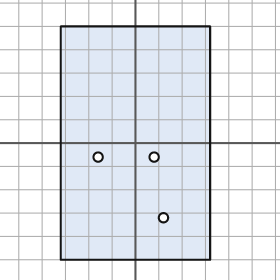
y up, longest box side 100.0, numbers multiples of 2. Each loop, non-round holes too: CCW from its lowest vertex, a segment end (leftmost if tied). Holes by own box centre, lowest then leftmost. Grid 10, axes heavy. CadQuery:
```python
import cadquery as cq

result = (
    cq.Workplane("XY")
    .moveTo(-32.0, -50.0)
    .lineTo(32.0, -50.0)
    .lineTo(32.0, 50.0)
    .lineTo(-32.0, 50.0)
    .close()
    .moveTo(12.0, -32.0)
    .circle(2.0)
    .moveTo(-16.0, -6.0)
    .circle(2.0)
    .moveTo(8.0, -6.0)
    .circle(2.0)
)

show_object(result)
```